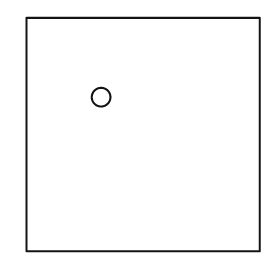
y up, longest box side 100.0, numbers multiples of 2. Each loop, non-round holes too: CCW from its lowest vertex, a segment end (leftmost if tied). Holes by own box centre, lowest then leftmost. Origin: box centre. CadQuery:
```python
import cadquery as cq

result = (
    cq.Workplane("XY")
    .moveTo(-50.0, -50.0)
    .lineTo(50.0, -50.0)
    .lineTo(50.0, 50.0)
    .lineTo(-50.0, 50.0)
    .close()
    .moveTo(-18.0, 16.0)
    .circle(4.0)
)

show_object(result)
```